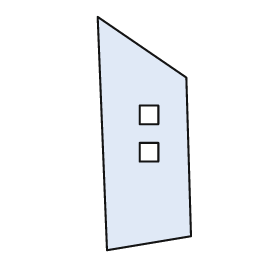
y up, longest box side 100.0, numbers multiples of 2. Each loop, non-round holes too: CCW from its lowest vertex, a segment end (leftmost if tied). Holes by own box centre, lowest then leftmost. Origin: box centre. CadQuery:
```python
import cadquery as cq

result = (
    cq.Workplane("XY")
    .moveTo(-16.0, -50.0)
    .lineTo(20.0, -44.0)
    .lineTo(18.0, 24.0)
    .lineTo(-20.0, 50.0)
    .close()
    .moveTo(-2.0, -12.0)
    .lineTo(6.0, -12.0)
    .lineTo(6.0, -4.0)
    .lineTo(-2.0, -4.0)
    .close()
    .moveTo(-2.0, 4.0)
    .lineTo(6.0, 4.0)
    .lineTo(6.0, 12.0)
    .lineTo(-2.0, 12.0)
    .close()
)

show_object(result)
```